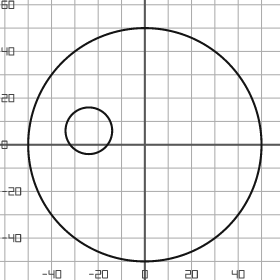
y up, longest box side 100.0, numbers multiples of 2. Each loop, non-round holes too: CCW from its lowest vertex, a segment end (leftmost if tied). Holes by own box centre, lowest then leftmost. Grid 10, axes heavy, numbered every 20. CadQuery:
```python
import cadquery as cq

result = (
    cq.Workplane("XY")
    .moveTo(0.0, 0.0)
    .circle(50.0)
    .moveTo(-24.0, 6.0)
    .circle(10.0)
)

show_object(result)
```